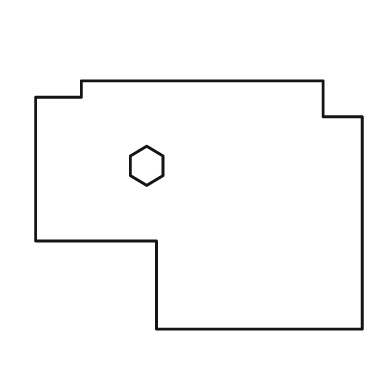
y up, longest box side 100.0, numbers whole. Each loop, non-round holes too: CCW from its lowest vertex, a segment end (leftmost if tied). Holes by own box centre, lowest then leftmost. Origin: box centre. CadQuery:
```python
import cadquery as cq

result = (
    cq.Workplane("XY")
    .moveTo(-13.0, -38.0)
    .lineTo(50.0, -38.0)
    .lineTo(50.0, 27.0)
    .lineTo(38.0, 27.0)
    .lineTo(38.0, 38.0)
    .lineTo(-36.0, 38.0)
    .lineTo(-36.0, 33.0)
    .lineTo(-50.0, 33.0)
    .lineTo(-50.0, -11.0)
    .lineTo(-13.0, -11.0)
    .close()
    .moveTo(-16.0, 6.0)
    .lineTo(-11.0, 9.0)
    .lineTo(-11.0, 15.0)
    .lineTo(-16.0, 18.0)
    .lineTo(-21.0, 15.0)
    .lineTo(-21.0, 9.0)
    .close()
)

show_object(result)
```